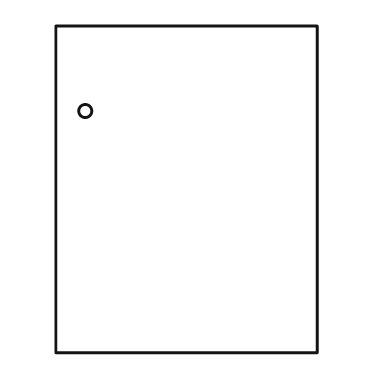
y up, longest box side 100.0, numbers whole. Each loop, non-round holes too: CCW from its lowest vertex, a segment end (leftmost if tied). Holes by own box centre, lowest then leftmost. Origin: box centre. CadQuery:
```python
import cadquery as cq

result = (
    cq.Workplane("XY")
    .moveTo(-40.0, -50.0)
    .lineTo(40.0, -50.0)
    .lineTo(40.0, 50.0)
    .lineTo(-40.0, 50.0)
    .close()
    .moveTo(-31.0, 24.0)
    .circle(2.0)
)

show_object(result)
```